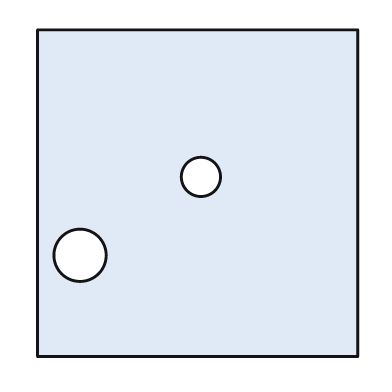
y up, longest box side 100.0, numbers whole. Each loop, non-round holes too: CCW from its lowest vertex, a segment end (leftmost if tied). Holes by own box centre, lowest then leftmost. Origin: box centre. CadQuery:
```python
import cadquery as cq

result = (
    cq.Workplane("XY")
    .moveTo(-49.0, -50.0)
    .lineTo(49.0, -50.0)
    .lineTo(49.0, 50.0)
    .lineTo(-49.0, 50.0)
    .close()
    .moveTo(-36.0, -19.0)
    .circle(8.0)
    .moveTo(1.0, 5.0)
    .circle(6.0)
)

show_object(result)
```